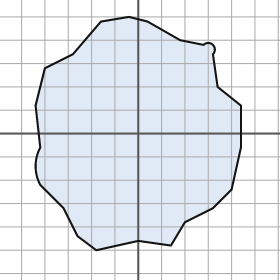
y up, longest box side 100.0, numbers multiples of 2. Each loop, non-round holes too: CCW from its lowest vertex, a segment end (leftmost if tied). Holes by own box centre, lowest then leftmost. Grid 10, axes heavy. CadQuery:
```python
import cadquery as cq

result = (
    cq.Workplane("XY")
    .moveTo(-18.0, -50.0)
    .lineTo(0.0, -46.0)
    .lineTo(14.0, -48.0)
    .lineTo(20.0, -38.0)
    .lineTo(32.0, -32.0)
    .lineTo(40.0, -24.0)
    .lineTo(44.0, -6.0)
    .lineTo(44.0, 12.0)
    .lineTo(34.0, 20.0)
    .lineTo(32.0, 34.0)
    .threePointArc((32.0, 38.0), (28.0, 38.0))
    .lineTo(18.0, 40.0)
    .lineTo(4.0, 48.0)
    .lineTo(-4.0, 50.0)
    .lineTo(-16.0, 48.0)
    .lineTo(-28.0, 34.0)
    .lineTo(-40.0, 28.0)
    .lineTo(-44.0, 12.0)
    .lineTo(-42.0, -6.0)
    .threePointArc((-44.0, -14.0), (-42.0, -22.0))
    .lineTo(-32.0, -32.0)
    .lineTo(-26.0, -44.0)
    .close()
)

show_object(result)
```